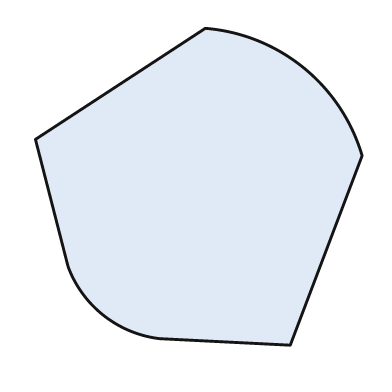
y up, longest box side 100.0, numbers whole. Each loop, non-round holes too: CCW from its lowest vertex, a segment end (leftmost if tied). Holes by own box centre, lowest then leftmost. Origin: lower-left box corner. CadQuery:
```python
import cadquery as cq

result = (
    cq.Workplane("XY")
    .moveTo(78.0, 0.0)
    .lineTo(100.0, 58.0)
    .threePointArc((82.0, 85.0), (52.0, 97.0))
    .lineTo(0.0, 63.0)
    .lineTo(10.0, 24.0)
    .threePointArc((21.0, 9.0), (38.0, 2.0))
    .close()
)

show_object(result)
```